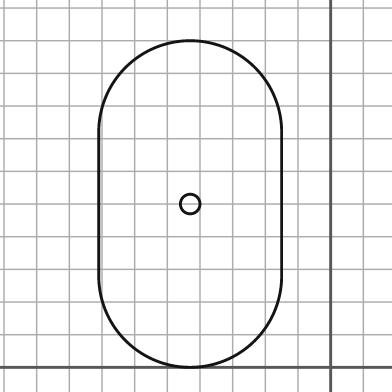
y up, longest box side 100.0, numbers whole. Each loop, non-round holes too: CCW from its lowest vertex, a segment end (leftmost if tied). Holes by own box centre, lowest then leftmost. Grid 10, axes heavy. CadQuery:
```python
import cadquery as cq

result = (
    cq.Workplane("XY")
    .moveTo(-71.0, 28.0)
    .threePointArc((-43.0, 0.0), (-15.0, 28.0))
    .lineTo(-15.0, 72.0)
    .threePointArc((-43.0, 100.0), (-71.0, 72.0))
    .close()
    .moveTo(-43.0, 50.0)
    .circle(3.0)
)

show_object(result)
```